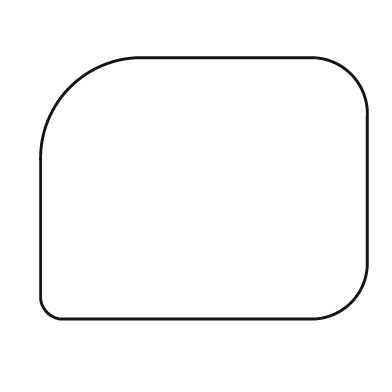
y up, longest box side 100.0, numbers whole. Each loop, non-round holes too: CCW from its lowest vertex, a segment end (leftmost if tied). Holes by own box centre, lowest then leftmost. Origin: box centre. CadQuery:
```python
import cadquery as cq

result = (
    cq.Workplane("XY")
    .moveTo(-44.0, -40.0)
    .lineTo(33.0, -40.0)
    .threePointArc((45.0, -35.0), (50.0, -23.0))
    .lineTo(50.0, 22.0)
    .threePointArc((45.0, 35.0), (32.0, 40.0))
    .lineTo(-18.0, 40.0)
    .threePointArc((-41.0, 31.0), (-50.0, 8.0))
    .lineTo(-50.0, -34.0)
    .threePointArc((-48.0, -38.0), (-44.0, -40.0))
    .close()
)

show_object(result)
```